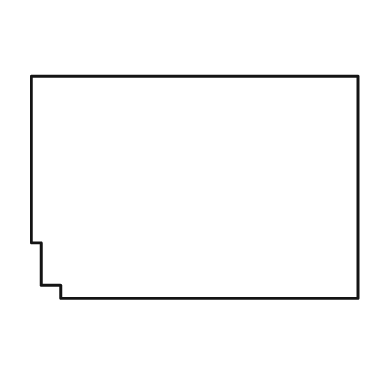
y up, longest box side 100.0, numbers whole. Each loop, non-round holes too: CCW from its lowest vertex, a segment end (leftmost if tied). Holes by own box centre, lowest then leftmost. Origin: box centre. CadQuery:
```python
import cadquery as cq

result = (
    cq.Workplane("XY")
    .moveTo(-41.0, -34.0)
    .lineTo(50.0, -34.0)
    .lineTo(50.0, 34.0)
    .lineTo(-50.0, 34.0)
    .lineTo(-50.0, -17.0)
    .lineTo(-47.0, -17.0)
    .lineTo(-47.0, -30.0)
    .lineTo(-41.0, -30.0)
    .close()
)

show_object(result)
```